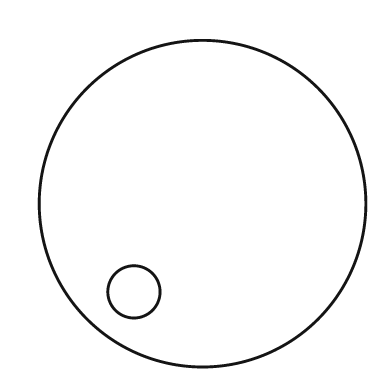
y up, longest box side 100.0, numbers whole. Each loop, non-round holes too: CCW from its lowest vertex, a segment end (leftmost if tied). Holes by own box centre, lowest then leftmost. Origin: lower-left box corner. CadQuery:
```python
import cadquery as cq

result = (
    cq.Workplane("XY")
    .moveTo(50.0, 50.0)
    .circle(50.0)
    .moveTo(29.0, 23.0)
    .circle(8.0)
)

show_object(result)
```